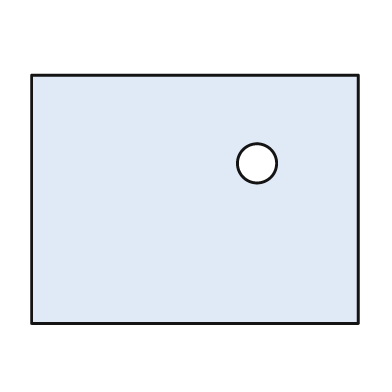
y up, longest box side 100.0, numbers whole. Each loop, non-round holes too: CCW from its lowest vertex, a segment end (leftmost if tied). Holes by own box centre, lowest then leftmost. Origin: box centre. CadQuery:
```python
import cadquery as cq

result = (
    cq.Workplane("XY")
    .moveTo(-50.0, -38.0)
    .lineTo(50.0, -38.0)
    .lineTo(50.0, 38.0)
    .lineTo(-50.0, 38.0)
    .close()
    .moveTo(19.0, 11.0)
    .circle(6.0)
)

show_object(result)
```